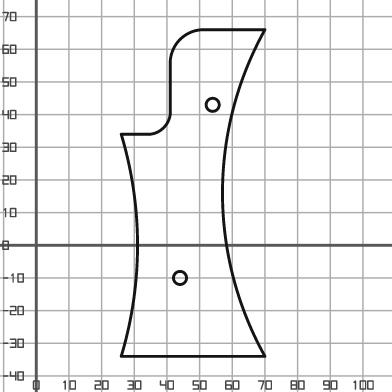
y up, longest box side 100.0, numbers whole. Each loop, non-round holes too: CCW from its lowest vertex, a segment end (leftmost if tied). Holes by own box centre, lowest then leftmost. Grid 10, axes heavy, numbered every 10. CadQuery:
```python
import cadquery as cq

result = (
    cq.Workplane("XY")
    .moveTo(26.0, -34.0)
    .lineTo(70.0, -34.0)
    .threePointArc((57.0, 16.0), (70.0, 66.0))
    .lineTo(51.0, 66.0)
    .threePointArc((44.0, 63.0), (41.0, 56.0))
    .lineTo(41.0, 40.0)
    .threePointArc((39.0, 36.0), (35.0, 34.0))
    .lineTo(26.0, 34.0)
    .threePointArc((31.0, 0.0), (26.0, -34.0))
    .close()
    .moveTo(44.0, -10.0)
    .circle(2.0)
    .moveTo(54.0, 43.0)
    .circle(2.0)
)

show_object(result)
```